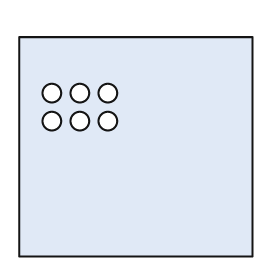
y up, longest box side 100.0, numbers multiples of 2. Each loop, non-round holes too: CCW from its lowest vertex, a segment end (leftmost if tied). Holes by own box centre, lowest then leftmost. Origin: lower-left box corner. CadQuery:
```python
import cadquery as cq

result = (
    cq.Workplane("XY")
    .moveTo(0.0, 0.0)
    .lineTo(100.0, 0.0)
    .lineTo(100.0, 94.0)
    .lineTo(0.0, 94.0)
    .close()
    .moveTo(14.0, 58.0)
    .circle(4.0)
    .moveTo(26.0, 58.0)
    .circle(4.0)
    .moveTo(38.0, 58.0)
    .circle(4.0)
    .moveTo(14.0, 70.0)
    .circle(4.0)
    .moveTo(26.0, 70.0)
    .circle(4.0)
    .moveTo(38.0, 70.0)
    .circle(4.0)
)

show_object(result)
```